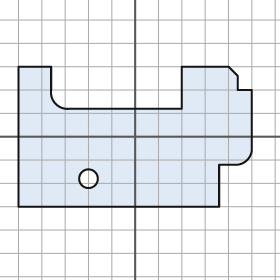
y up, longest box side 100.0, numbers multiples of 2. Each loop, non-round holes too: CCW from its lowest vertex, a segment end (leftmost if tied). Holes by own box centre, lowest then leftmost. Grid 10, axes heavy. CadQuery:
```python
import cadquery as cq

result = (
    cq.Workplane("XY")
    .moveTo(-50.0, -30.0)
    .lineTo(36.0, -30.0)
    .lineTo(36.0, -12.0)
    .lineTo(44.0, -12.0)
    .threePointArc((48.0, -10.0), (50.0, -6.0))
    .lineTo(50.0, 20.0)
    .lineTo(44.0, 20.0)
    .lineTo(44.0, 26.0)
    .lineTo(40.0, 30.0)
    .lineTo(20.0, 30.0)
    .lineTo(20.0, 12.0)
    .lineTo(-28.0, 12.0)
    .threePointArc((-34.0, 14.0), (-36.0, 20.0))
    .lineTo(-36.0, 30.0)
    .lineTo(-50.0, 30.0)
    .close()
    .moveTo(-20.0, -18.0)
    .circle(4.0)
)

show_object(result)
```